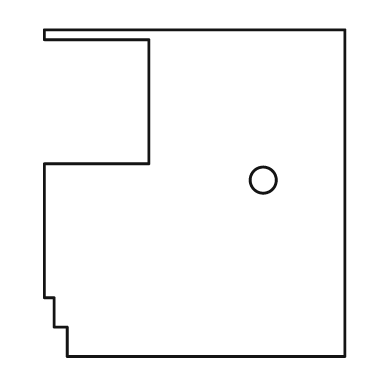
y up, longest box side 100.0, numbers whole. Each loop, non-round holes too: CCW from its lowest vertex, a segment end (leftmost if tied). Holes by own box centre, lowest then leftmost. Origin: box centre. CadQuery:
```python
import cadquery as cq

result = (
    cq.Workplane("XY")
    .moveTo(-39.0, -50.0)
    .lineTo(46.0, -50.0)
    .lineTo(46.0, 50.0)
    .lineTo(-46.0, 50.0)
    .lineTo(-46.0, 47.0)
    .lineTo(-14.0, 47.0)
    .lineTo(-14.0, 9.0)
    .lineTo(-46.0, 9.0)
    .lineTo(-46.0, -32.0)
    .lineTo(-43.0, -32.0)
    .lineTo(-43.0, -41.0)
    .lineTo(-39.0, -41.0)
    .close()
    .moveTo(21.0, 4.0)
    .circle(4.0)
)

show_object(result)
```